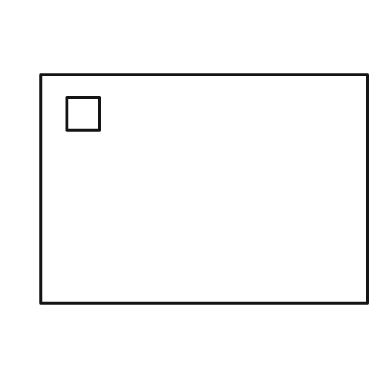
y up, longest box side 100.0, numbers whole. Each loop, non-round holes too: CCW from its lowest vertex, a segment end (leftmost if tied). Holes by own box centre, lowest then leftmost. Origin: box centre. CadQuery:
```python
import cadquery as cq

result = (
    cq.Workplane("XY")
    .moveTo(-50.0, -35.0)
    .lineTo(50.0, -35.0)
    .lineTo(50.0, 35.0)
    .lineTo(-50.0, 35.0)
    .close()
    .moveTo(-42.0, 18.0)
    .lineTo(-32.0, 18.0)
    .lineTo(-32.0, 28.0)
    .lineTo(-42.0, 28.0)
    .close()
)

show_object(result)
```